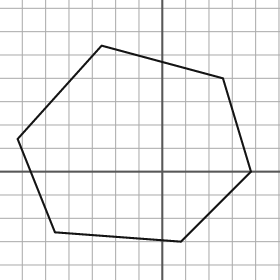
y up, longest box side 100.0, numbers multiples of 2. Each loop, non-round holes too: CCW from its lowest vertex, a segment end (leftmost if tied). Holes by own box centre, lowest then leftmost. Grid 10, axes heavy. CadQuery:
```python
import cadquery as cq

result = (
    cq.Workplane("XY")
    .moveTo(8.0, -30.0)
    .lineTo(38.0, 0.0)
    .lineTo(26.0, 40.0)
    .lineTo(-26.0, 54.0)
    .lineTo(-62.0, 14.0)
    .lineTo(-46.0, -26.0)
    .close()
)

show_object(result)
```